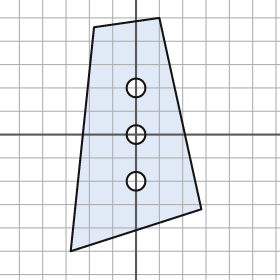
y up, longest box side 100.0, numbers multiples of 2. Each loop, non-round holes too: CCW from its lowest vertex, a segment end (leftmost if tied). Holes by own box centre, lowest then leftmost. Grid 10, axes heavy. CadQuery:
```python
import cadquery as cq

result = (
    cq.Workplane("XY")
    .moveTo(-28.0, -50.0)
    .lineTo(28.0, -32.0)
    .lineTo(10.0, 50.0)
    .lineTo(-18.0, 46.0)
    .close()
    .moveTo(0.0, -20.0)
    .circle(4.0)
    .moveTo(0.0, 0.0)
    .circle(4.0)
    .moveTo(0.0, 20.0)
    .circle(4.0)
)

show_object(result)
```